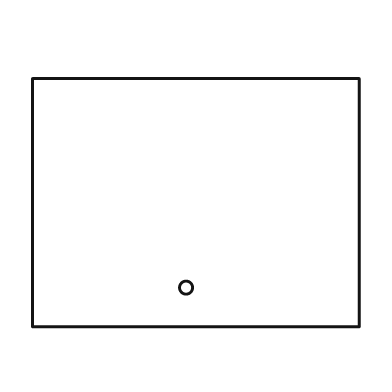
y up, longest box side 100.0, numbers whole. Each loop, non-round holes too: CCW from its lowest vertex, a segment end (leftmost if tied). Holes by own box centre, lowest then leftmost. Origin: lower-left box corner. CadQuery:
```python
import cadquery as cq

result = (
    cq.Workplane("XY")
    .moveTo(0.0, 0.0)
    .lineTo(100.0, 0.0)
    .lineTo(100.0, 76.0)
    .lineTo(0.0, 76.0)
    .close()
    .moveTo(47.0, 12.0)
    .circle(2.0)
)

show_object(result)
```